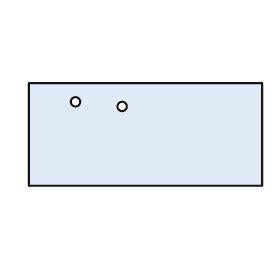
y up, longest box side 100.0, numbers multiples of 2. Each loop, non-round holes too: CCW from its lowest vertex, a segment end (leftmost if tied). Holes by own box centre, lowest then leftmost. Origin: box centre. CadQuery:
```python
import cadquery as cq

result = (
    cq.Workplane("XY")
    .moveTo(-50.0, -22.0)
    .lineTo(50.0, -22.0)
    .lineTo(50.0, 22.0)
    .lineTo(-50.0, 22.0)
    .close()
    .moveTo(-10.0, 12.0)
    .circle(2.0)
    .moveTo(-30.0, 14.0)
    .circle(2.0)
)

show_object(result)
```